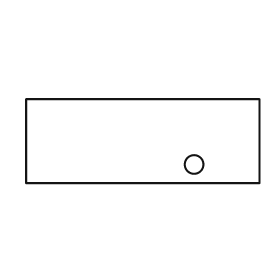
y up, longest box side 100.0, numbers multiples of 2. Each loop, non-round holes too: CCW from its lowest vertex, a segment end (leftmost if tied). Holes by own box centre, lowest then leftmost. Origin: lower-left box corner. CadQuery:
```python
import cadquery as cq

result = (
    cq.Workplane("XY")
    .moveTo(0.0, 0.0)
    .lineTo(100.0, 0.0)
    .lineTo(100.0, 36.0)
    .lineTo(0.0, 36.0)
    .close()
    .moveTo(72.0, 8.0)
    .circle(4.0)
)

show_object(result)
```